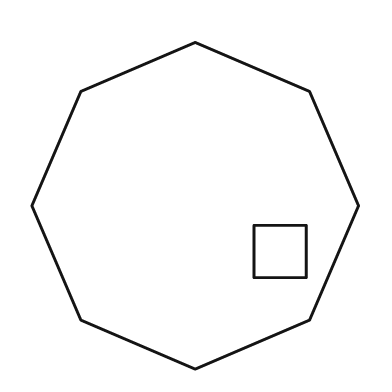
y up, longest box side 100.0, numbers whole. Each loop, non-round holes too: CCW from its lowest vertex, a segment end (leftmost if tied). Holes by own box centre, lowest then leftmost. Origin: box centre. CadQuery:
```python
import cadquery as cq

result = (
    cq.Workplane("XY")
    .moveTo(0.0, -50.0)
    .lineTo(35.0, -35.0)
    .lineTo(50.0, 0.0)
    .lineTo(35.0, 35.0)
    .lineTo(0.0, 50.0)
    .lineTo(-35.0, 35.0)
    .lineTo(-50.0, 0.0)
    .lineTo(-35.0, -35.0)
    .close()
    .moveTo(18.0, -22.0)
    .lineTo(34.0, -22.0)
    .lineTo(34.0, -6.0)
    .lineTo(18.0, -6.0)
    .close()
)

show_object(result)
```